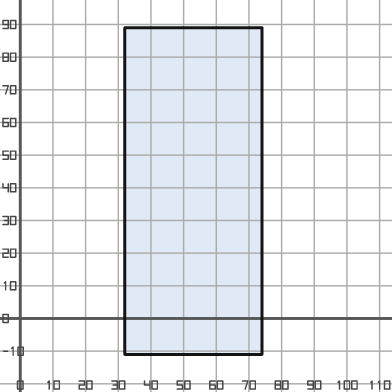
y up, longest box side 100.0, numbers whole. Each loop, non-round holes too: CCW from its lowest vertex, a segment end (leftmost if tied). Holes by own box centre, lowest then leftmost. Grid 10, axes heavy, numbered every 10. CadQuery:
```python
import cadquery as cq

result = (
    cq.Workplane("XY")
    .moveTo(32.0, -11.0)
    .lineTo(74.0, -11.0)
    .lineTo(74.0, 89.0)
    .lineTo(32.0, 89.0)
    .close()
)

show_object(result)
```